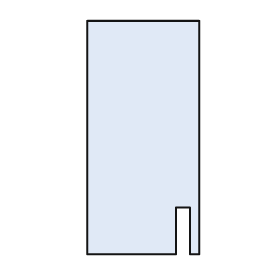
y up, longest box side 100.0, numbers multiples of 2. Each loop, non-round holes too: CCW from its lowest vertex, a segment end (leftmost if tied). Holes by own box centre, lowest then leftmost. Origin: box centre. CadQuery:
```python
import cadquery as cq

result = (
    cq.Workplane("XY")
    .moveTo(-24.0, -50.0)
    .lineTo(14.0, -50.0)
    .lineTo(14.0, -30.0)
    .lineTo(20.0, -30.0)
    .lineTo(20.0, -50.0)
    .lineTo(24.0, -50.0)
    .lineTo(24.0, 50.0)
    .lineTo(-24.0, 50.0)
    .close()
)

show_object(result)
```